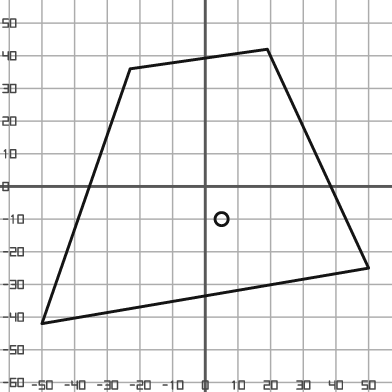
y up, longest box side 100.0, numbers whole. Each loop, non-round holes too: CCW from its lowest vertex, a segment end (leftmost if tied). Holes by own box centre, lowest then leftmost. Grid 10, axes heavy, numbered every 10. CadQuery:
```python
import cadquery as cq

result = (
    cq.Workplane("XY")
    .moveTo(-50.0, -42.0)
    .lineTo(50.0, -25.0)
    .lineTo(19.0, 42.0)
    .lineTo(-23.0, 36.0)
    .close()
    .moveTo(5.0, -10.0)
    .circle(2.0)
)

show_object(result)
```